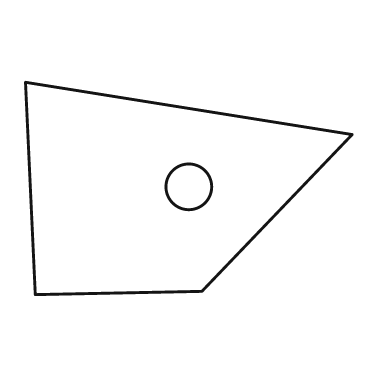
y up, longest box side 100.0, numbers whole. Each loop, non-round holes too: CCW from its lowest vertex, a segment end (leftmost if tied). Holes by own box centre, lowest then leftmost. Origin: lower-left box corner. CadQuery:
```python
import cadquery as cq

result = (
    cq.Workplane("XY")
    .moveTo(3.0, 0.0)
    .lineTo(54.0, 1.0)
    .lineTo(100.0, 49.0)
    .lineTo(0.0, 65.0)
    .close()
    .moveTo(50.0, 33.0)
    .circle(7.0)
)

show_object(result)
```